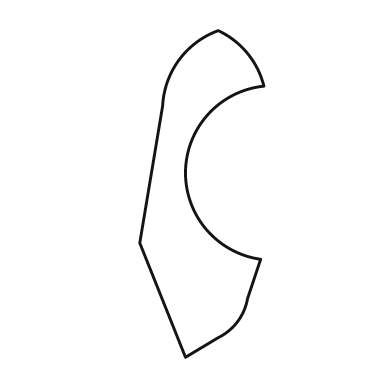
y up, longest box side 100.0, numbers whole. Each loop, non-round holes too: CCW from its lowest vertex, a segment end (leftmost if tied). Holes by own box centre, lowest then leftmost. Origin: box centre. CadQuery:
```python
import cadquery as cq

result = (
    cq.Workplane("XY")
    .moveTo(-5.0, -50.0)
    .lineTo(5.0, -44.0)
    .threePointArc((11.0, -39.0), (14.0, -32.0))
    .lineTo(18.0, -20.0)
    .threePointArc((-5.0, 7.0), (19.0, 33.0))
    .threePointArc((14.0, 43.0), (5.0, 50.0))
    .threePointArc((-7.0, 41.0), (-12.0, 27.0))
    .lineTo(-19.0, -15.0)
    .close()
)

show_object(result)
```